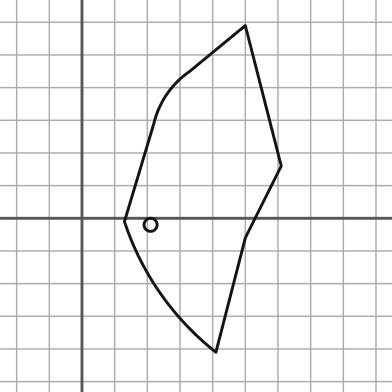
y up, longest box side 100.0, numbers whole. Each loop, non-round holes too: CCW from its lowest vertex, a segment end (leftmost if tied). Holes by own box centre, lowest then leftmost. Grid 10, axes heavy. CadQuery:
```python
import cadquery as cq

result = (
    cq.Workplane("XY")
    .moveTo(41.0, -41.0)
    .lineTo(50.0, -6.0)
    .lineTo(61.0, 16.0)
    .lineTo(50.0, 59.0)
    .lineTo(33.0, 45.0)
    .threePointArc((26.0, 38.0), (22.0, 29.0))
    .lineTo(13.0, -1.0)
    .threePointArc((24.0, -23.0), (41.0, -41.0))
    .close()
    .moveTo(21.0, -2.0)
    .circle(2.0)
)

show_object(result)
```